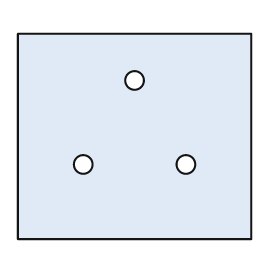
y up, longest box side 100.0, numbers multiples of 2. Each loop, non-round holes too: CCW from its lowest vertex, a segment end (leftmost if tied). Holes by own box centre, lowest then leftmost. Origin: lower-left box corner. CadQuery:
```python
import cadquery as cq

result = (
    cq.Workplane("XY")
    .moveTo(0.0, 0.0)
    .lineTo(100.0, 0.0)
    .lineTo(100.0, 88.0)
    .lineTo(0.0, 88.0)
    .close()
    .moveTo(28.0, 32.0)
    .circle(4.0)
    .moveTo(72.0, 32.0)
    .circle(4.0)
    .moveTo(50.0, 68.0)
    .circle(4.0)
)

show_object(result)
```